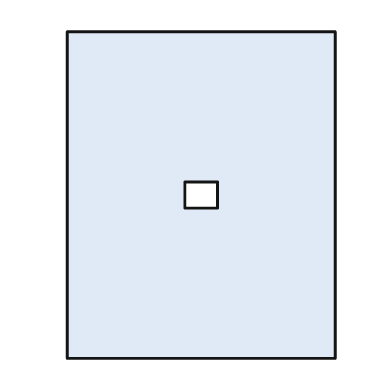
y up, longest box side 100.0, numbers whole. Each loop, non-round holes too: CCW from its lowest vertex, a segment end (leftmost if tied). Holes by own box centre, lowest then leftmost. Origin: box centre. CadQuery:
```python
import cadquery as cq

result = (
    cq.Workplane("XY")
    .moveTo(-41.0, -50.0)
    .lineTo(41.0, -50.0)
    .lineTo(41.0, 50.0)
    .lineTo(-41.0, 50.0)
    .close()
    .moveTo(-5.0, -4.0)
    .lineTo(5.0, -4.0)
    .lineTo(5.0, 4.0)
    .lineTo(-5.0, 4.0)
    .close()
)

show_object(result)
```